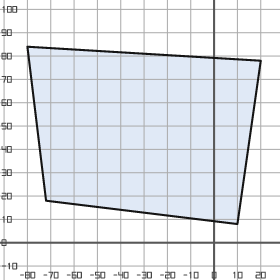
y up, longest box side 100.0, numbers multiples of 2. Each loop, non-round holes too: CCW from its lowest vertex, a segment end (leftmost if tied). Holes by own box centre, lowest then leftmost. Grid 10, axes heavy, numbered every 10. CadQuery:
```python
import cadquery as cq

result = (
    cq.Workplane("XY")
    .moveTo(10.0, 8.0)
    .lineTo(20.0, 78.0)
    .lineTo(-80.0, 84.0)
    .lineTo(-72.0, 18.0)
    .close()
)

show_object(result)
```